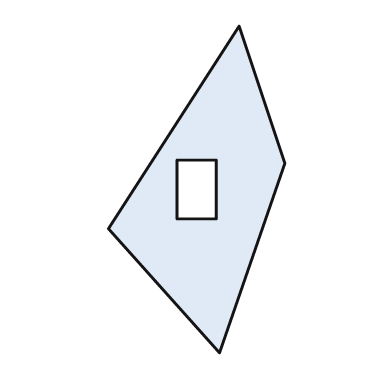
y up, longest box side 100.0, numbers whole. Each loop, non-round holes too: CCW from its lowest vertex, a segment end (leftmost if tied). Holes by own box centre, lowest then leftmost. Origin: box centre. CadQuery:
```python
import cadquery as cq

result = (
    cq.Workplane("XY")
    .moveTo(7.0, -50.0)
    .lineTo(27.0, 8.0)
    .lineTo(13.0, 50.0)
    .lineTo(-27.0, -12.0)
    .close()
    .moveTo(-6.0, -9.0)
    .lineTo(6.0, -9.0)
    .lineTo(6.0, 9.0)
    .lineTo(-6.0, 9.0)
    .close()
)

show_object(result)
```